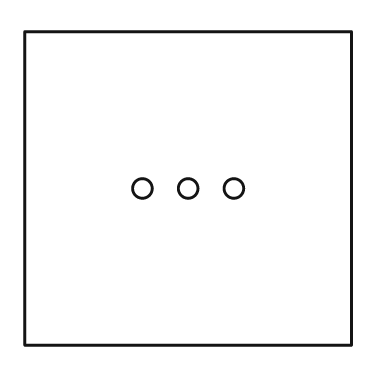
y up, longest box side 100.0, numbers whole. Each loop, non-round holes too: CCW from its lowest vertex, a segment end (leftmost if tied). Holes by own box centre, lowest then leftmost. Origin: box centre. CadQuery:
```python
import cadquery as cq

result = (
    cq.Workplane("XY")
    .moveTo(-50.0, -48.0)
    .lineTo(50.0, -48.0)
    .lineTo(50.0, 48.0)
    .lineTo(-50.0, 48.0)
    .close()
    .moveTo(-14.0, 0.0)
    .circle(3.0)
    .moveTo(0.0, 0.0)
    .circle(3.0)
    .moveTo(14.0, 0.0)
    .circle(3.0)
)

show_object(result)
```